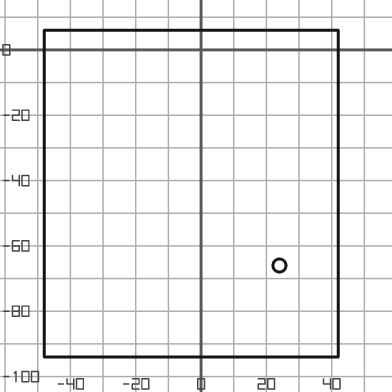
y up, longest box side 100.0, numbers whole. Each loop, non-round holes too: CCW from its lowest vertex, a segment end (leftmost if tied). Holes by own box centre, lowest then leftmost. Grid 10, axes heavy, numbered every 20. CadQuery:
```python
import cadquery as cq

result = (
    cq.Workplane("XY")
    .moveTo(-48.0, -94.0)
    .lineTo(42.0, -94.0)
    .lineTo(42.0, 6.0)
    .lineTo(-48.0, 6.0)
    .close()
    .moveTo(24.0, -66.0)
    .circle(2.0)
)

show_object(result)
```